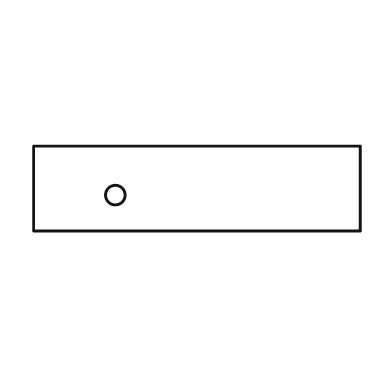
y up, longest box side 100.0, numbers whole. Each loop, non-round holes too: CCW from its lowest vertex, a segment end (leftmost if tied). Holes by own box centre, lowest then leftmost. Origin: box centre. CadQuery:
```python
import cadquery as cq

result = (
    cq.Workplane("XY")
    .moveTo(-50.0, -13.0)
    .lineTo(50.0, -13.0)
    .lineTo(50.0, 13.0)
    .lineTo(-50.0, 13.0)
    .close()
    .moveTo(-25.0, -2.0)
    .circle(3.0)
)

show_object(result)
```